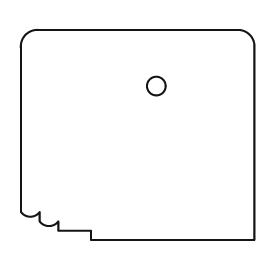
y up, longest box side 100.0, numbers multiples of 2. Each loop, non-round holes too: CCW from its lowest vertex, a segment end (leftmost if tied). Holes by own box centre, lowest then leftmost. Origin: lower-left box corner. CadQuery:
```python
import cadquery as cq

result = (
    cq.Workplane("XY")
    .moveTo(30.0, 0.0)
    .lineTo(100.0, 0.0)
    .lineTo(100.0, 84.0)
    .threePointArc((98.0, 88.0), (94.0, 90.0))
    .lineTo(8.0, 90.0)
    .threePointArc((2.0, 88.0), (0.0, 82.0))
    .lineTo(0.0, 12.0)
    .threePointArc((4.0, 10.0), (8.0, 12.0))
    .lineTo(8.0, 8.0)
    .threePointArc((12.0, 6.0), (16.0, 8.0))
    .lineTo(16.0, 4.0)
    .lineTo(30.0, 4.0)
    .close()
    .moveTo(58.0, 66.0)
    .circle(4.0)
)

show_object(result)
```